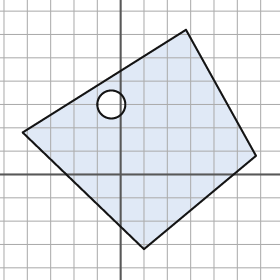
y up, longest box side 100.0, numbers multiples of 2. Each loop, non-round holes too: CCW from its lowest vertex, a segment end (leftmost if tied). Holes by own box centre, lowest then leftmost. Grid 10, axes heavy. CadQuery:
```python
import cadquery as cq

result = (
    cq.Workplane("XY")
    .moveTo(10.0, -32.0)
    .lineTo(58.0, 8.0)
    .lineTo(28.0, 62.0)
    .lineTo(-42.0, 18.0)
    .close()
    .moveTo(-4.0, 30.0)
    .circle(6.0)
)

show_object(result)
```